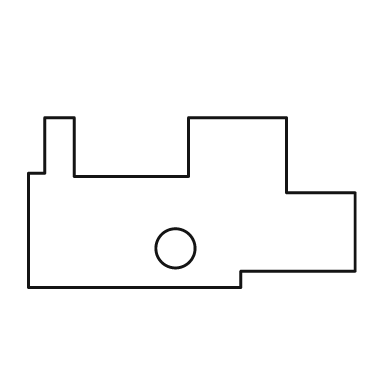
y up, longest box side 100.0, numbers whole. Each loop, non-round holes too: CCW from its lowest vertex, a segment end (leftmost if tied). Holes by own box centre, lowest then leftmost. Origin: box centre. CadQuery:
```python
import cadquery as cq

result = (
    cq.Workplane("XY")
    .moveTo(-50.0, -26.0)
    .lineTo(15.0, -26.0)
    .lineTo(15.0, -21.0)
    .lineTo(50.0, -21.0)
    .lineTo(50.0, 3.0)
    .lineTo(29.0, 3.0)
    .lineTo(29.0, 26.0)
    .lineTo(-1.0, 26.0)
    .lineTo(-1.0, 8.0)
    .lineTo(-36.0, 8.0)
    .lineTo(-36.0, 26.0)
    .lineTo(-45.0, 26.0)
    .lineTo(-45.0, 9.0)
    .lineTo(-50.0, 9.0)
    .close()
    .moveTo(-5.0, -14.0)
    .circle(6.0)
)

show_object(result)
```